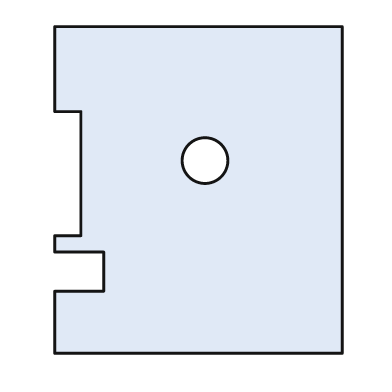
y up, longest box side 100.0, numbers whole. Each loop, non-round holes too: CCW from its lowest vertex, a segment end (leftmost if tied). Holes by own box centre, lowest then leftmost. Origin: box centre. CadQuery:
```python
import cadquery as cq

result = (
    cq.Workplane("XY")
    .moveTo(-44.0, -50.0)
    .lineTo(44.0, -50.0)
    .lineTo(44.0, 50.0)
    .lineTo(-44.0, 50.0)
    .lineTo(-44.0, 24.0)
    .lineTo(-36.0, 24.0)
    .lineTo(-36.0, -14.0)
    .lineTo(-44.0, -14.0)
    .lineTo(-44.0, -19.0)
    .lineTo(-29.0, -19.0)
    .lineTo(-29.0, -31.0)
    .lineTo(-44.0, -31.0)
    .close()
    .moveTo(2.0, 9.0)
    .circle(7.0)
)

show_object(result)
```